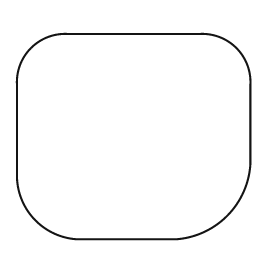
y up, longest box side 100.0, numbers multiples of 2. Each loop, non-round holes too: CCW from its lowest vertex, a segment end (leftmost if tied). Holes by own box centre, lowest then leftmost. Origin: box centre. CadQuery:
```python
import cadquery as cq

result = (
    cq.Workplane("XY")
    .moveTo(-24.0, -44.0)
    .lineTo(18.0, -44.0)
    .threePointArc((40.0, -34.0), (50.0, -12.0))
    .lineTo(50.0, 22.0)
    .threePointArc((44.0, 38.0), (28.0, 44.0))
    .lineTo(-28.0, 44.0)
    .threePointArc((-44.0, 38.0), (-50.0, 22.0))
    .lineTo(-50.0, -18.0)
    .threePointArc((-42.0, -36.0), (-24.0, -44.0))
    .close()
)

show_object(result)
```